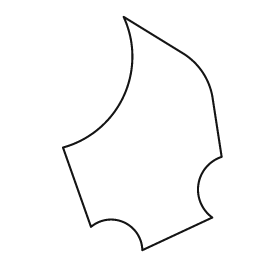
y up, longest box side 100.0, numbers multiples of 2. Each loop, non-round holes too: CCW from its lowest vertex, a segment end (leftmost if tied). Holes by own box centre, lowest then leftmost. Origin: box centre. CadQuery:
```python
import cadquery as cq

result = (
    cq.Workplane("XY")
    .moveTo(0.0, -50.0)
    .lineTo(30.0, -36.0)
    .threePointArc((24.0, -22.0), (34.0, -10.0))
    .lineTo(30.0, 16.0)
    .threePointArc((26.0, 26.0), (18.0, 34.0))
    .lineTo(-8.0, 50.0)
    .threePointArc((-8.0, 16.0), (-34.0, -6.0))
    .lineTo(-22.0, -40.0)
    .threePointArc((-8.0, -38.0), (0.0, -50.0))
    .close()
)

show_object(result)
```